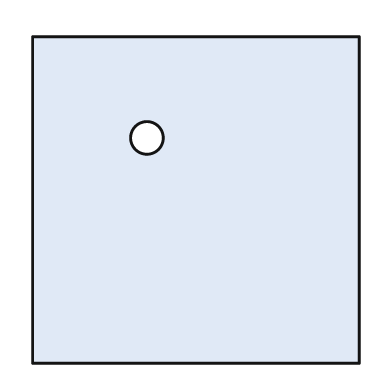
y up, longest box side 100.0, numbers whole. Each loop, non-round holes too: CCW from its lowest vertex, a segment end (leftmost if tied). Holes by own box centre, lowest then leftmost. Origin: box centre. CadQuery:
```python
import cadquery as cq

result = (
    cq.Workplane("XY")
    .moveTo(-50.0, -50.0)
    .lineTo(50.0, -50.0)
    .lineTo(50.0, 50.0)
    .lineTo(-50.0, 50.0)
    .close()
    .moveTo(-15.0, 19.0)
    .circle(5.0)
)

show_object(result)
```